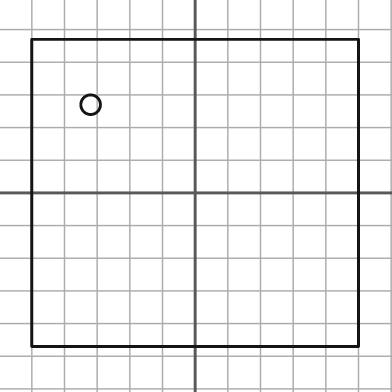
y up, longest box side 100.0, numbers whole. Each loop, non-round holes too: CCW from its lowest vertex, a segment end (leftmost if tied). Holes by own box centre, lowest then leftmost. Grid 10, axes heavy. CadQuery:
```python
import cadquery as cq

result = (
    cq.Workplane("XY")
    .moveTo(-50.0, -47.0)
    .lineTo(50.0, -47.0)
    .lineTo(50.0, 47.0)
    .lineTo(-50.0, 47.0)
    .close()
    .moveTo(-32.0, 27.0)
    .circle(3.0)
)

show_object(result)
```